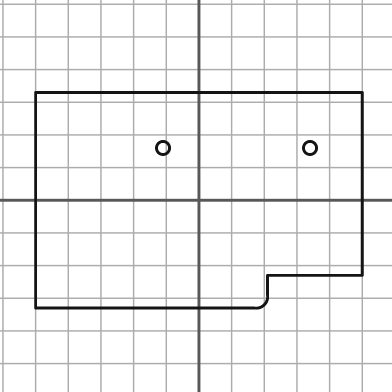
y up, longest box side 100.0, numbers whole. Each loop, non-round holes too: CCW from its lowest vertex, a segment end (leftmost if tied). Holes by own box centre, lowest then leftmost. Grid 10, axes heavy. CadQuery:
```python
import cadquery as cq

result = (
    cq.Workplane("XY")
    .moveTo(-50.0, -33.0)
    .lineTo(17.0, -33.0)
    .threePointArc((20.0, -32.0), (21.0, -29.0))
    .lineTo(21.0, -23.0)
    .lineTo(50.0, -23.0)
    .lineTo(50.0, 33.0)
    .lineTo(-50.0, 33.0)
    .close()
    .moveTo(-11.0, 16.0)
    .circle(2.0)
    .moveTo(34.0, 16.0)
    .circle(2.0)
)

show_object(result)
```